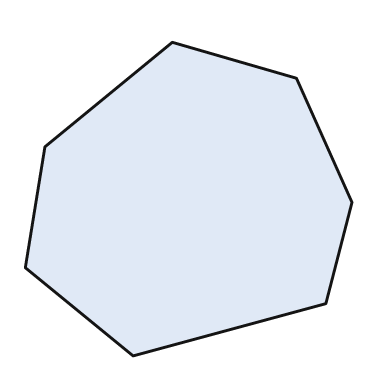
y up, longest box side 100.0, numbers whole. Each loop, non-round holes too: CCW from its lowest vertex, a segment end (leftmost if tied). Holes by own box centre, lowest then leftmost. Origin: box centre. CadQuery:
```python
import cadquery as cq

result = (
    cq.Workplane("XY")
    .moveTo(-17.0, -48.0)
    .lineTo(42.0, -32.0)
    .lineTo(50.0, -1.0)
    .lineTo(33.0, 37.0)
    .lineTo(-5.0, 48.0)
    .lineTo(-44.0, 16.0)
    .lineTo(-50.0, -21.0)
    .close()
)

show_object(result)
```